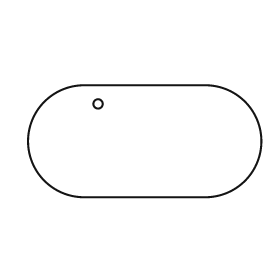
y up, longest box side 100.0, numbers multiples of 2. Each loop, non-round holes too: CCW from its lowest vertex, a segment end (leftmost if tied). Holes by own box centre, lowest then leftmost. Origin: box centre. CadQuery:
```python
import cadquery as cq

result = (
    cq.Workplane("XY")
    .moveTo(-26.0, -24.0)
    .lineTo(26.0, -24.0)
    .threePointArc((50.0, 0.0), (26.0, 24.0))
    .lineTo(-26.0, 24.0)
    .threePointArc((-50.0, 0.0), (-26.0, -24.0))
    .close()
    .moveTo(-20.0, 16.0)
    .circle(2.0)
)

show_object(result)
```